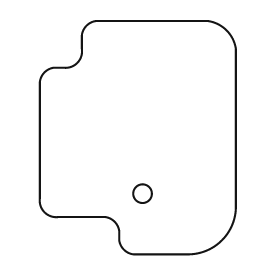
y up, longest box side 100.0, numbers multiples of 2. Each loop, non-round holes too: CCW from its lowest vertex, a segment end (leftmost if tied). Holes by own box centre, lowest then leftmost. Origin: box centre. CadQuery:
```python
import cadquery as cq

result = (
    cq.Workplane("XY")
    .moveTo(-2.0, -50.0)
    .lineTo(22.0, -50.0)
    .threePointArc((36.0, -44.0), (42.0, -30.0))
    .lineTo(42.0, 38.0)
    .threePointArc((38.0, 46.0), (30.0, 50.0))
    .lineTo(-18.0, 50.0)
    .threePointArc((-22.0, 48.0), (-24.0, 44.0))
    .lineTo(-24.0, 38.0)
    .threePointArc((-26.0, 32.0), (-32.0, 30.0))
    .lineTo(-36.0, 30.0)
    .threePointArc((-40.0, 28.0), (-42.0, 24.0))
    .lineTo(-42.0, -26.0)
    .threePointArc((-40.0, -32.0), (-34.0, -34.0))
    .lineTo(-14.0, -34.0)
    .threePointArc((-10.0, -36.0), (-8.0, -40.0))
    .lineTo(-8.0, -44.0)
    .threePointArc((-6.0, -48.0), (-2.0, -50.0))
    .close()
    .moveTo(2.0, -24.0)
    .circle(4.0)
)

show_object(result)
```